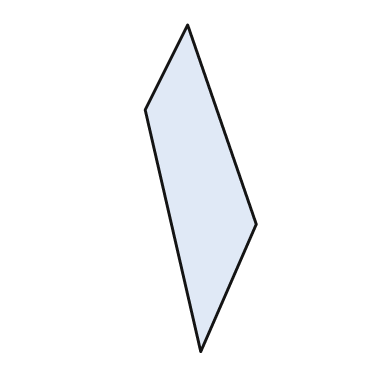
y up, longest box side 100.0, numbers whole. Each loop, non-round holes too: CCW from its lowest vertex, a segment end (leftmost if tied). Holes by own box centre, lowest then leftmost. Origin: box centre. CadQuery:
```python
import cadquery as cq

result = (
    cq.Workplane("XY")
    .moveTo(0.0, -50.0)
    .lineTo(17.0, -11.0)
    .lineTo(-4.0, 50.0)
    .lineTo(-17.0, 24.0)
    .close()
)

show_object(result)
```